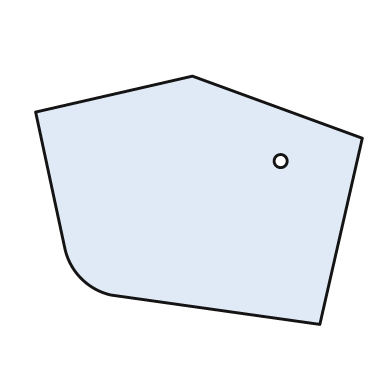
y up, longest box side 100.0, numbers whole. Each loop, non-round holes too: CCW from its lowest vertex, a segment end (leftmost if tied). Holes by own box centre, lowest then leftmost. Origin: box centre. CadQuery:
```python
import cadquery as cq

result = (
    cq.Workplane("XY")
    .moveTo(37.0, -38.0)
    .lineTo(50.0, 19.0)
    .lineTo(-2.0, 38.0)
    .lineTo(-50.0, 27.0)
    .lineTo(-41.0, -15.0)
    .threePointArc((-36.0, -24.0), (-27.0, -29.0))
    .close()
    .moveTo(25.0, 12.0)
    .circle(2.0)
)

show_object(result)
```